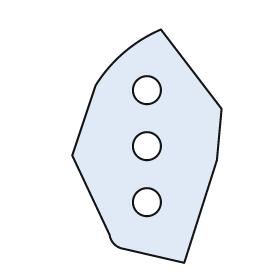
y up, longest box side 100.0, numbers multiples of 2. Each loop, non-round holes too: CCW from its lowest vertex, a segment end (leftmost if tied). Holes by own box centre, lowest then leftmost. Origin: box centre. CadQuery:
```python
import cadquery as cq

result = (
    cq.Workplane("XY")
    .moveTo(16.0, -50.0)
    .lineTo(30.0, -6.0)
    .lineTo(32.0, 16.0)
    .lineTo(6.0, 50.0)
    .threePointArc((-10.0, 40.0), (-22.0, 26.0))
    .lineTo(-32.0, -4.0)
    .lineTo(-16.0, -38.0)
    .threePointArc((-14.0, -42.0), (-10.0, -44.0))
    .close()
    .moveTo(0.0, -24.0)
    .circle(6.0)
    .moveTo(0.0, 0.0)
    .circle(6.0)
    .moveTo(0.0, 24.0)
    .circle(6.0)
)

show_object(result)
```